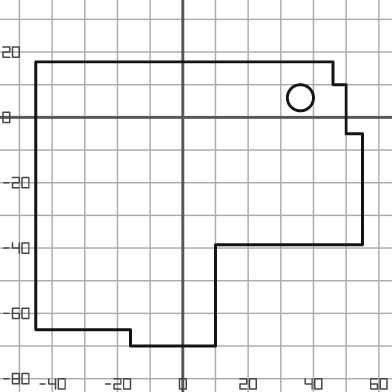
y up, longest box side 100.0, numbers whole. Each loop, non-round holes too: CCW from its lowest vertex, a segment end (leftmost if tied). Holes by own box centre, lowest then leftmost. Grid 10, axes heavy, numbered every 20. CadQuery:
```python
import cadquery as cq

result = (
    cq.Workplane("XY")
    .moveTo(-16.0, -70.0)
    .lineTo(10.0, -70.0)
    .lineTo(10.0, -39.0)
    .lineTo(55.0, -39.0)
    .lineTo(55.0, -5.0)
    .lineTo(50.0, -5.0)
    .lineTo(50.0, 10.0)
    .lineTo(46.0, 10.0)
    .lineTo(46.0, 17.0)
    .lineTo(-45.0, 17.0)
    .lineTo(-45.0, -65.0)
    .lineTo(-16.0, -65.0)
    .close()
    .moveTo(36.0, 6.0)
    .circle(4.0)
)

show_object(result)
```